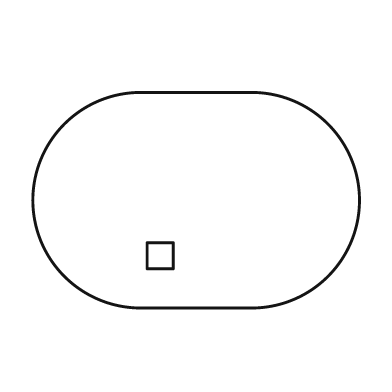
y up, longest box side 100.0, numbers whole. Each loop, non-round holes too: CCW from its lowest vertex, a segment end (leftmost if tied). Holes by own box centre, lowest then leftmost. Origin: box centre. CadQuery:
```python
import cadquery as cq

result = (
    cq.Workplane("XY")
    .moveTo(-17.0, -33.0)
    .lineTo(17.0, -33.0)
    .threePointArc((50.0, 0.0), (17.0, 33.0))
    .lineTo(-17.0, 33.0)
    .threePointArc((-50.0, 0.0), (-17.0, -33.0))
    .close()
    .moveTo(-15.0, -21.0)
    .lineTo(-7.0, -21.0)
    .lineTo(-7.0, -13.0)
    .lineTo(-15.0, -13.0)
    .close()
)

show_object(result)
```